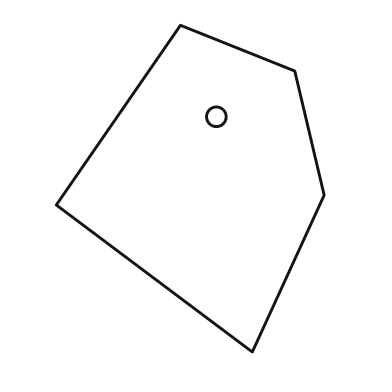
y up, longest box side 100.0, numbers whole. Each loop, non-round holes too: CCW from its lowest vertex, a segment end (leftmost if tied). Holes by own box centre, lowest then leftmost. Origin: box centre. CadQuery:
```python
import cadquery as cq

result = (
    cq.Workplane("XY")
    .moveTo(19.0, -50.0)
    .lineTo(41.0, -2.0)
    .lineTo(32.0, 36.0)
    .lineTo(-3.0, 50.0)
    .lineTo(-41.0, -5.0)
    .close()
    .moveTo(8.0, 22.0)
    .circle(3.0)
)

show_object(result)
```